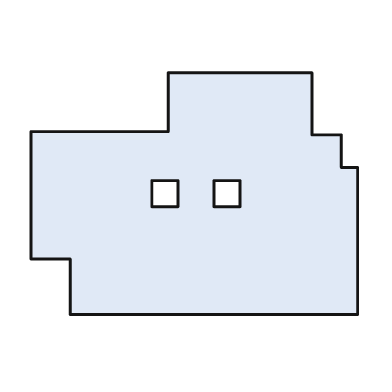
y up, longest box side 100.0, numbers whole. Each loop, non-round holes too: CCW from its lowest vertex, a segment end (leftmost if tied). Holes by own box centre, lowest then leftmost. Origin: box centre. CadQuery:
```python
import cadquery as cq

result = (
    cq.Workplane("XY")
    .moveTo(-38.0, -37.0)
    .lineTo(50.0, -37.0)
    .lineTo(50.0, 8.0)
    .lineTo(45.0, 8.0)
    .lineTo(45.0, 18.0)
    .lineTo(36.0, 18.0)
    .lineTo(36.0, 37.0)
    .lineTo(-8.0, 37.0)
    .lineTo(-8.0, 19.0)
    .lineTo(-50.0, 19.0)
    .lineTo(-50.0, -20.0)
    .lineTo(-38.0, -20.0)
    .close()
    .moveTo(-13.0, -4.0)
    .lineTo(-5.0, -4.0)
    .lineTo(-5.0, 4.0)
    .lineTo(-13.0, 4.0)
    .close()
    .moveTo(6.0, -4.0)
    .lineTo(14.0, -4.0)
    .lineTo(14.0, 4.0)
    .lineTo(6.0, 4.0)
    .close()
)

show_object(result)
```